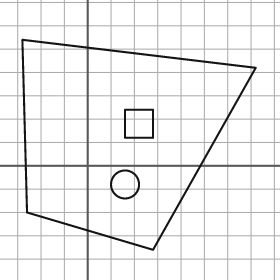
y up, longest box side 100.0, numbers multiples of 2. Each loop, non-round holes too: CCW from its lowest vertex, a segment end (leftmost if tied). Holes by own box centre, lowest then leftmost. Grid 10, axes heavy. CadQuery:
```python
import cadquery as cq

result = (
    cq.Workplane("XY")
    .moveTo(28.0, -36.0)
    .lineTo(72.0, 42.0)
    .lineTo(-28.0, 54.0)
    .lineTo(-26.0, -20.0)
    .close()
    .moveTo(16.0, -8.0)
    .circle(6.0)
    .moveTo(16.0, 12.0)
    .lineTo(28.0, 12.0)
    .lineTo(28.0, 24.0)
    .lineTo(16.0, 24.0)
    .close()
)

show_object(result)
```